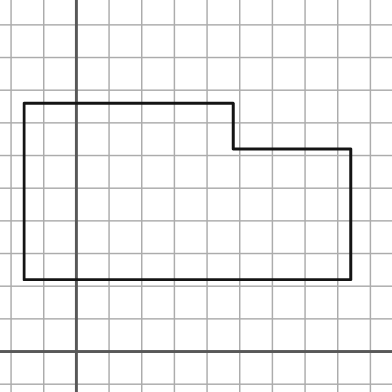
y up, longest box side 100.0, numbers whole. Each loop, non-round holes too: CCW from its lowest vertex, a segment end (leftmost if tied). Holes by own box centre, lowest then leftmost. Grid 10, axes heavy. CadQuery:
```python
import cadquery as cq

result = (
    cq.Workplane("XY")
    .moveTo(-16.0, 22.0)
    .lineTo(84.0, 22.0)
    .lineTo(84.0, 62.0)
    .lineTo(48.0, 62.0)
    .lineTo(48.0, 76.0)
    .lineTo(-16.0, 76.0)
    .close()
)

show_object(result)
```